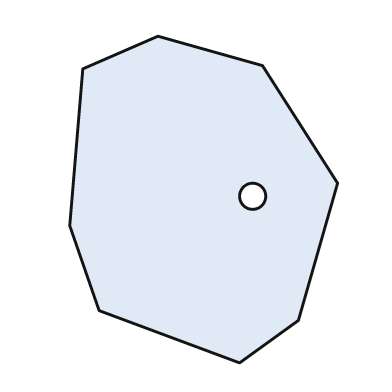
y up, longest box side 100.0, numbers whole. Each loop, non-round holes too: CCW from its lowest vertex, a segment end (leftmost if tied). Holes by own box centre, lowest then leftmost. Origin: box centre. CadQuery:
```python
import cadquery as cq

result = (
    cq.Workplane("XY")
    .moveTo(11.0, -50.0)
    .lineTo(29.0, -37.0)
    .lineTo(41.0, 5.0)
    .lineTo(18.0, 41.0)
    .lineTo(-14.0, 50.0)
    .lineTo(-37.0, 40.0)
    .lineTo(-41.0, -8.0)
    .lineTo(-32.0, -34.0)
    .close()
    .moveTo(15.0, 1.0)
    .circle(4.0)
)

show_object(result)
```